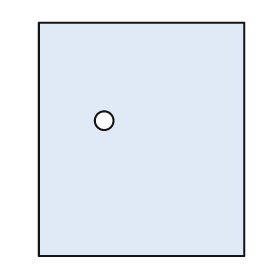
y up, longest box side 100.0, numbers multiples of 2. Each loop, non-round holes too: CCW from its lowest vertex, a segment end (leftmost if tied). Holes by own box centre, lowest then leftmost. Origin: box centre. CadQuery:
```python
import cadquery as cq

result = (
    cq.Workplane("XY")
    .moveTo(-44.0, -50.0)
    .lineTo(44.0, -50.0)
    .lineTo(44.0, 50.0)
    .lineTo(-44.0, 50.0)
    .close()
    .moveTo(-16.0, 8.0)
    .circle(4.0)
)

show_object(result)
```